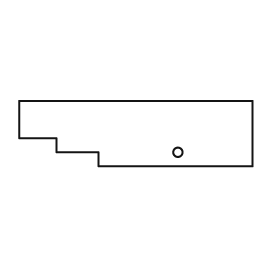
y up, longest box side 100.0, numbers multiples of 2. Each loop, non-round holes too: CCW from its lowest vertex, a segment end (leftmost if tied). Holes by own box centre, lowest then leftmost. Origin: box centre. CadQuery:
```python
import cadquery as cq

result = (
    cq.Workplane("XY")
    .moveTo(-16.0, -14.0)
    .lineTo(50.0, -14.0)
    .lineTo(50.0, 14.0)
    .lineTo(-50.0, 14.0)
    .lineTo(-50.0, -2.0)
    .lineTo(-34.0, -2.0)
    .lineTo(-34.0, -8.0)
    .lineTo(-16.0, -8.0)
    .close()
    .moveTo(18.0, -8.0)
    .circle(2.0)
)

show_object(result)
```